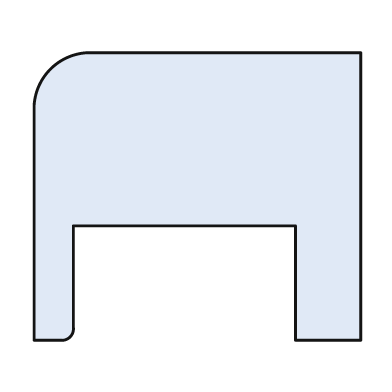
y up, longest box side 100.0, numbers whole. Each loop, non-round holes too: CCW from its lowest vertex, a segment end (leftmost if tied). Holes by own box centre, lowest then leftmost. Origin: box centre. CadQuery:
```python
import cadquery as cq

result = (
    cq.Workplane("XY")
    .moveTo(-50.0, -44.0)
    .lineTo(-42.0, -44.0)
    .threePointArc((-39.0, -43.0), (-38.0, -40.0))
    .lineTo(-38.0, -9.0)
    .lineTo(30.0, -9.0)
    .lineTo(30.0, -44.0)
    .lineTo(50.0, -44.0)
    .lineTo(50.0, 44.0)
    .lineTo(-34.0, 44.0)
    .threePointArc((-45.0, 39.0), (-50.0, 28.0))
    .close()
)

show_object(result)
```